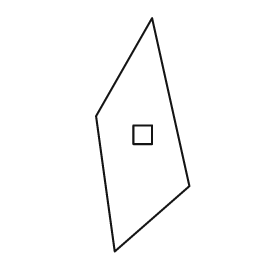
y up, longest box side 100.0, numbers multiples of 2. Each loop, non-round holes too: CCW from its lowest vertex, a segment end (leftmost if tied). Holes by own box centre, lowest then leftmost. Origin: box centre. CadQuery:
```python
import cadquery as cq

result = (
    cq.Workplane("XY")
    .moveTo(-12.0, -50.0)
    .lineTo(20.0, -22.0)
    .lineTo(4.0, 50.0)
    .lineTo(-20.0, 8.0)
    .close()
    .moveTo(-4.0, -4.0)
    .lineTo(4.0, -4.0)
    .lineTo(4.0, 4.0)
    .lineTo(-4.0, 4.0)
    .close()
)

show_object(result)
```